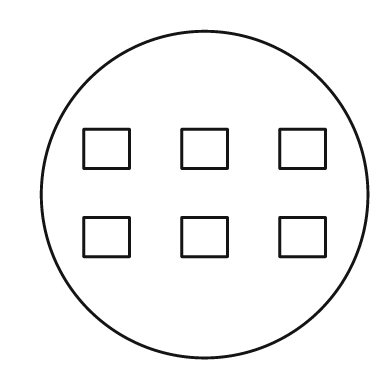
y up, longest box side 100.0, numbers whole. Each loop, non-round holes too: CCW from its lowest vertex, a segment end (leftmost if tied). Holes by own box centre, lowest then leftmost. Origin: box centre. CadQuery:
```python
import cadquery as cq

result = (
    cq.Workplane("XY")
    .moveTo(0.0, 0.0)
    .circle(50.0)
    .moveTo(-37.0, -19.0)
    .lineTo(-23.0, -19.0)
    .lineTo(-23.0, -7.0)
    .lineTo(-37.0, -7.0)
    .close()
    .moveTo(-7.0, -19.0)
    .lineTo(7.0, -19.0)
    .lineTo(7.0, -7.0)
    .lineTo(-7.0, -7.0)
    .close()
    .moveTo(23.0, -19.0)
    .lineTo(37.0, -19.0)
    .lineTo(37.0, -7.0)
    .lineTo(23.0, -7.0)
    .close()
    .moveTo(-37.0, 8.0)
    .lineTo(-23.0, 8.0)
    .lineTo(-23.0, 20.0)
    .lineTo(-37.0, 20.0)
    .close()
    .moveTo(-7.0, 8.0)
    .lineTo(7.0, 8.0)
    .lineTo(7.0, 20.0)
    .lineTo(-7.0, 20.0)
    .close()
    .moveTo(23.0, 8.0)
    .lineTo(37.0, 8.0)
    .lineTo(37.0, 20.0)
    .lineTo(23.0, 20.0)
    .close()
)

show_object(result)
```